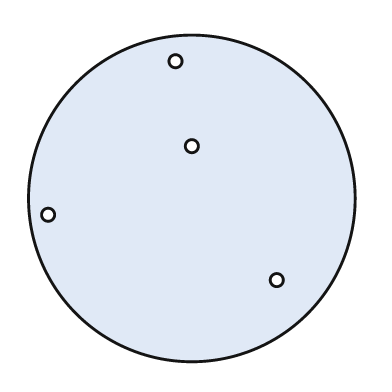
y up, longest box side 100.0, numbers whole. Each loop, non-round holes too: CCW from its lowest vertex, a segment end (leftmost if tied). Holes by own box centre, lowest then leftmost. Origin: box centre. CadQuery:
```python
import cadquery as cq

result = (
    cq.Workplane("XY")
    .moveTo(0.0, 0.0)
    .circle(50.0)
    .moveTo(26.0, -25.0)
    .circle(2.0)
    .moveTo(-44.0, -5.0)
    .circle(2.0)
    .moveTo(0.0, 16.0)
    .circle(2.0)
    .moveTo(-5.0, 42.0)
    .circle(2.0)
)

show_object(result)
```